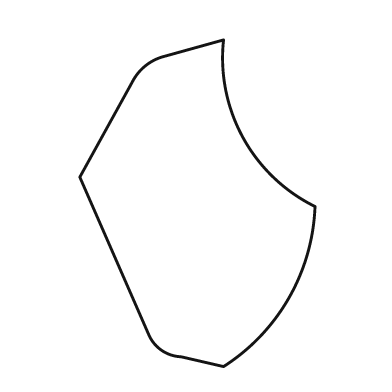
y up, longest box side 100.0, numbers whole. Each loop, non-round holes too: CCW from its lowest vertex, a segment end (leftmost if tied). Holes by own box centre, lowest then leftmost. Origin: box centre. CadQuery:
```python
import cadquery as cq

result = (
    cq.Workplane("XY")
    .moveTo(8.0, -50.0)
    .threePointArc((28.0, -29.0), (36.0, -1.0))
    .threePointArc((14.0, 20.0), (8.0, 50.0))
    .lineTo(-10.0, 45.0)
    .threePointArc((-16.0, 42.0), (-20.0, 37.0))
    .lineTo(-36.0, 8.0)
    .lineTo(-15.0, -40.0)
    .threePointArc((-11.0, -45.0), (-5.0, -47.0))
    .close()
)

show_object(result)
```